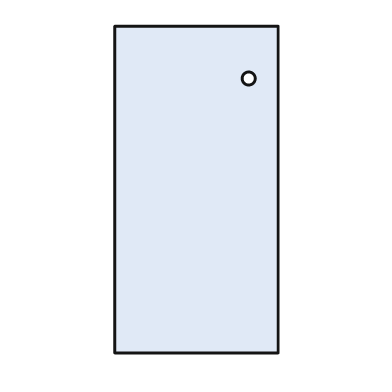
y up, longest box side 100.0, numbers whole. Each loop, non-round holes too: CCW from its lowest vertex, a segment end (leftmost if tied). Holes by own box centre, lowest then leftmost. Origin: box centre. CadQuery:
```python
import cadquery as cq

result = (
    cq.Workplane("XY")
    .moveTo(-25.0, -50.0)
    .lineTo(25.0, -50.0)
    .lineTo(25.0, 50.0)
    .lineTo(-25.0, 50.0)
    .close()
    .moveTo(16.0, 34.0)
    .circle(2.0)
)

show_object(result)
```